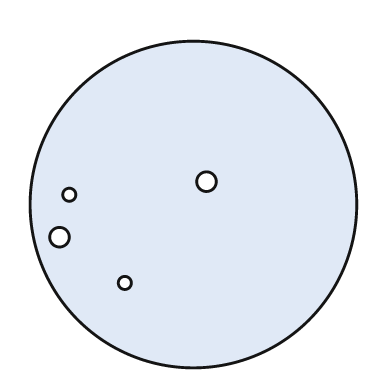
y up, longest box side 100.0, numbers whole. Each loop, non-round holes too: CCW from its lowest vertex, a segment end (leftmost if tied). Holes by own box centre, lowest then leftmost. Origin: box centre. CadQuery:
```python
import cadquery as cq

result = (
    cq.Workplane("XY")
    .moveTo(0.0, 0.0)
    .circle(50.0)
    .moveTo(-21.0, -24.0)
    .circle(2.0)
    .moveTo(-41.0, -10.0)
    .circle(3.0)
    .moveTo(-38.0, 3.0)
    .circle(2.0)
    .moveTo(4.0, 7.0)
    .circle(3.0)
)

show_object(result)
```